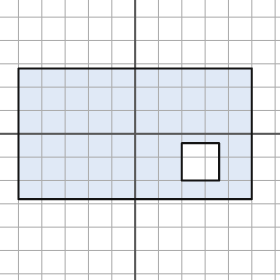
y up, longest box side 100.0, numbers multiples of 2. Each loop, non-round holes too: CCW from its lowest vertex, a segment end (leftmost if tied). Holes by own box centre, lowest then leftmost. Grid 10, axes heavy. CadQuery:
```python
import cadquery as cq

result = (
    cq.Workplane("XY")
    .moveTo(-50.0, -28.0)
    .lineTo(50.0, -28.0)
    .lineTo(50.0, 28.0)
    .lineTo(-50.0, 28.0)
    .close()
    .moveTo(20.0, -20.0)
    .lineTo(36.0, -20.0)
    .lineTo(36.0, -4.0)
    .lineTo(20.0, -4.0)
    .close()
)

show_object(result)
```